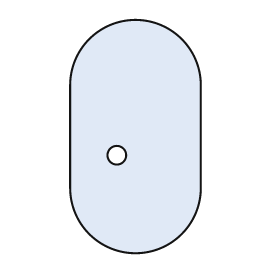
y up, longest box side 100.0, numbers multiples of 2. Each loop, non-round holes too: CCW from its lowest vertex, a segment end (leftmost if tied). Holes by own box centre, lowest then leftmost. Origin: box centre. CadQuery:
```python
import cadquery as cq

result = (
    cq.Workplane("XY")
    .moveTo(-28.0, -22.0)
    .threePointArc((0.0, -50.0), (28.0, -22.0))
    .lineTo(28.0, 22.0)
    .threePointArc((0.0, 50.0), (-28.0, 22.0))
    .close()
    .moveTo(-8.0, -8.0)
    .circle(4.0)
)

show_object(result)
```